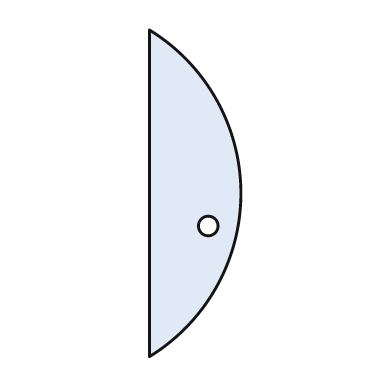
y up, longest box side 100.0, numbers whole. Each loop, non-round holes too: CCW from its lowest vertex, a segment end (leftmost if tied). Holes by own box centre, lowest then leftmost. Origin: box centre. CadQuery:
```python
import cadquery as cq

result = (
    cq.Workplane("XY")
    .moveTo(-14.0, -50.0)
    .threePointArc((14.0, 0.0), (-14.0, 50.0))
    .close()
    .moveTo(4.0, -10.0)
    .circle(3.0)
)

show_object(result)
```